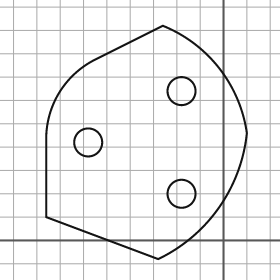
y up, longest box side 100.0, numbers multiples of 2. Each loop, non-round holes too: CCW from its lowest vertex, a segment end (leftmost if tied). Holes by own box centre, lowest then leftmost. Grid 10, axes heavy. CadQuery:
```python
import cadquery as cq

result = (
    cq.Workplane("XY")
    .moveTo(-28.0, -8.0)
    .threePointArc((-2.0, 14.0), (10.0, 46.0))
    .threePointArc((-2.0, 74.0), (-26.0, 92.0))
    .lineTo(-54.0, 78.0)
    .threePointArc((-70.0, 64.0), (-76.0, 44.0))
    .lineTo(-76.0, 10.0)
    .close()
    .moveTo(-18.0, 20.0)
    .circle(6.0)
    .moveTo(-58.0, 42.0)
    .circle(6.0)
    .moveTo(-18.0, 64.0)
    .circle(6.0)
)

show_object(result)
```